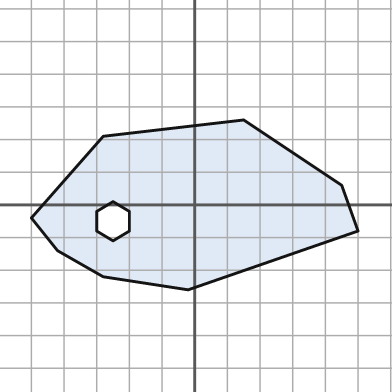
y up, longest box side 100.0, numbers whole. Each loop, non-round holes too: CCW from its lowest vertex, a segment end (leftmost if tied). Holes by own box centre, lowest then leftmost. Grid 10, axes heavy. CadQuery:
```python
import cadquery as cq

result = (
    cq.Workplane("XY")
    .moveTo(-2.0, -26.0)
    .lineTo(50.0, -8.0)
    .lineTo(45.0, 6.0)
    .lineTo(15.0, 26.0)
    .lineTo(-28.0, 21.0)
    .lineTo(-50.0, -4.0)
    .lineTo(-42.0, -14.0)
    .lineTo(-28.0, -22.0)
    .close()
    .moveTo(-25.0, -11.0)
    .lineTo(-20.0, -8.0)
    .lineTo(-20.0, -2.0)
    .lineTo(-25.0, 1.0)
    .lineTo(-30.0, -2.0)
    .lineTo(-30.0, -8.0)
    .close()
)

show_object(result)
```